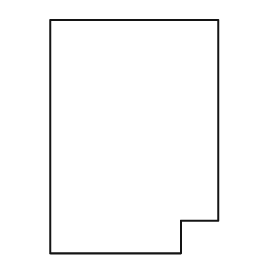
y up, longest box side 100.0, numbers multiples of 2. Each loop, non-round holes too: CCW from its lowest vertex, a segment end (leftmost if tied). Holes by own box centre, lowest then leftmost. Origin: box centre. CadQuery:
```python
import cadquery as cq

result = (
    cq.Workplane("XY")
    .moveTo(-36.0, -50.0)
    .lineTo(20.0, -50.0)
    .lineTo(20.0, -36.0)
    .lineTo(36.0, -36.0)
    .lineTo(36.0, 50.0)
    .lineTo(-36.0, 50.0)
    .close()
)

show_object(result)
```